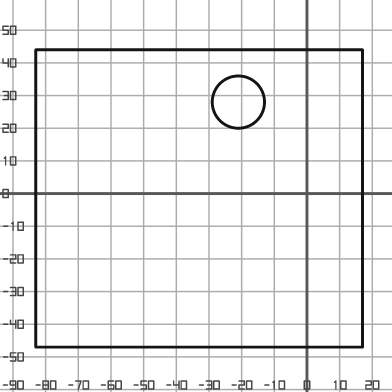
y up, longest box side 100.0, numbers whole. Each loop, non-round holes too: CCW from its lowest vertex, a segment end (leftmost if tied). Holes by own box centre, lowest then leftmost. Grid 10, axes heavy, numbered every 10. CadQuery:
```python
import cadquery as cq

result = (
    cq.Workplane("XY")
    .moveTo(-83.0, -47.0)
    .lineTo(17.0, -47.0)
    .lineTo(17.0, 44.0)
    .lineTo(-83.0, 44.0)
    .close()
    .moveTo(-21.0, 28.0)
    .circle(8.0)
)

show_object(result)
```